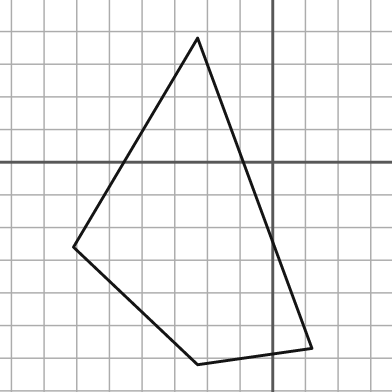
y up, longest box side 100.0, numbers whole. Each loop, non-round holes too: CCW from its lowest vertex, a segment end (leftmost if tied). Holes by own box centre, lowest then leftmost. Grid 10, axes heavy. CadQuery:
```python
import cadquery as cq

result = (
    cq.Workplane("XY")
    .moveTo(-23.0, -62.0)
    .lineTo(12.0, -57.0)
    .lineTo(-23.0, 38.0)
    .lineTo(-61.0, -26.0)
    .close()
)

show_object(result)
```